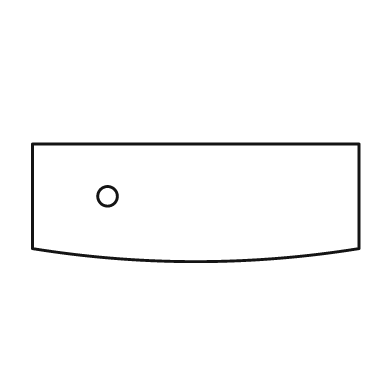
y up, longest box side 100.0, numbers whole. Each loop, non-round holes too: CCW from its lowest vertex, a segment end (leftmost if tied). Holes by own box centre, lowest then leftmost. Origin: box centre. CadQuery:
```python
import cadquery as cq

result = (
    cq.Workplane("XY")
    .moveTo(-50.0, -14.0)
    .threePointArc((0.0, -18.0), (50.0, -14.0))
    .lineTo(50.0, 18.0)
    .lineTo(-50.0, 18.0)
    .close()
    .moveTo(-27.0, 2.0)
    .circle(3.0)
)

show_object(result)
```